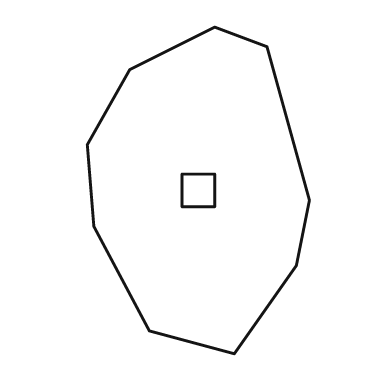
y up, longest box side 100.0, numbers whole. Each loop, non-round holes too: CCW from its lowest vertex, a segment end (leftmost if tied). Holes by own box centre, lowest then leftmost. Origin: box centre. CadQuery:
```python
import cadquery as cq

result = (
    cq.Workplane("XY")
    .moveTo(11.0, -50.0)
    .lineTo(30.0, -23.0)
    .lineTo(34.0, -3.0)
    .lineTo(21.0, 44.0)
    .lineTo(5.0, 50.0)
    .lineTo(-21.0, 37.0)
    .lineTo(-34.0, 14.0)
    .lineTo(-32.0, -11.0)
    .lineTo(-15.0, -43.0)
    .close()
    .moveTo(-5.0, -5.0)
    .lineTo(5.0, -5.0)
    .lineTo(5.0, 5.0)
    .lineTo(-5.0, 5.0)
    .close()
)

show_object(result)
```